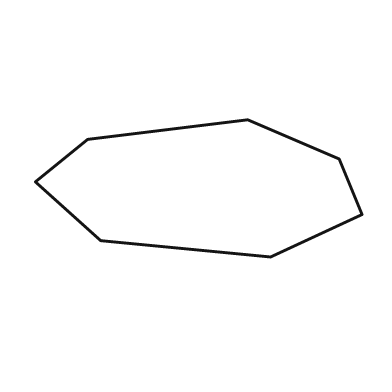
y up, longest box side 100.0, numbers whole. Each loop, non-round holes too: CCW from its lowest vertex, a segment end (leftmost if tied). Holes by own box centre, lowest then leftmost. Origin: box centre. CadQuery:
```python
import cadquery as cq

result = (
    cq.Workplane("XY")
    .moveTo(22.0, -21.0)
    .lineTo(50.0, -8.0)
    .lineTo(43.0, 9.0)
    .lineTo(15.0, 21.0)
    .lineTo(-34.0, 15.0)
    .lineTo(-50.0, 2.0)
    .lineTo(-30.0, -16.0)
    .close()
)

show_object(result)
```